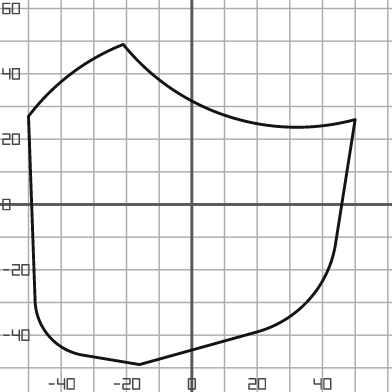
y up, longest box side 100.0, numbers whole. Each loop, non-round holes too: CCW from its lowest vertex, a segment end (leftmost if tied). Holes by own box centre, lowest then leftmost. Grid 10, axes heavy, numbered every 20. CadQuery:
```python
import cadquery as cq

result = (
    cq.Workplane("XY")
    .moveTo(-16.0, -49.0)
    .lineTo(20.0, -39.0)
    .threePointArc((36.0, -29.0), (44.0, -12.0))
    .lineTo(50.0, 26.0)
    .threePointArc((11.0, 27.0), (-21.0, 49.0))
    .threePointArc((-37.0, 40.0), (-50.0, 27.0))
    .lineTo(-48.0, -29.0)
    .threePointArc((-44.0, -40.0), (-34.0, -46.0))
    .close()
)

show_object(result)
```